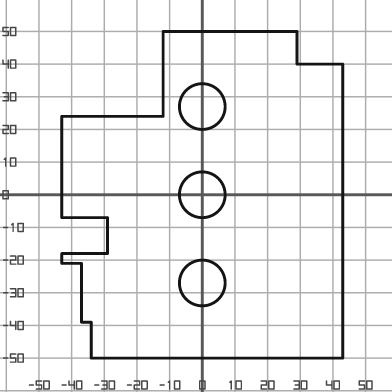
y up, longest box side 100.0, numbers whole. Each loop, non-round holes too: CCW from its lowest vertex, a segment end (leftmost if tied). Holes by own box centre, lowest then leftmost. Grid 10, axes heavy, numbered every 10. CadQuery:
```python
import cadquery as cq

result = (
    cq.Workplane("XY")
    .moveTo(-34.0, -50.0)
    .lineTo(43.0, -50.0)
    .lineTo(43.0, 40.0)
    .lineTo(29.0, 40.0)
    .lineTo(29.0, 50.0)
    .lineTo(-12.0, 50.0)
    .lineTo(-12.0, 24.0)
    .lineTo(-43.0, 24.0)
    .lineTo(-43.0, -7.0)
    .lineTo(-29.0, -7.0)
    .lineTo(-29.0, -18.0)
    .lineTo(-43.0, -18.0)
    .lineTo(-43.0, -21.0)
    .lineTo(-37.0, -21.0)
    .lineTo(-37.0, -39.0)
    .lineTo(-34.0, -39.0)
    .close()
    .moveTo(0.0, -27.0)
    .circle(7.0)
    .moveTo(0.0, 0.0)
    .circle(7.0)
    .moveTo(0.0, 27.0)
    .circle(7.0)
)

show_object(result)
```